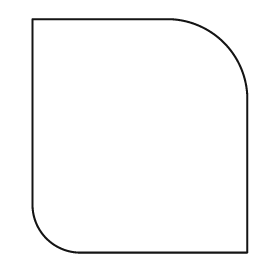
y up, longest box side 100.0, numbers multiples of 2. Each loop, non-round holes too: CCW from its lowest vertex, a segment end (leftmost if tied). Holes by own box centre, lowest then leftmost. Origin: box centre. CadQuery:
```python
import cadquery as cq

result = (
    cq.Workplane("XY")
    .moveTo(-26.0, -50.0)
    .lineTo(46.0, -50.0)
    .lineTo(46.0, 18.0)
    .threePointArc((36.0, 40.0), (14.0, 50.0))
    .lineTo(-46.0, 50.0)
    .lineTo(-46.0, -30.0)
    .threePointArc((-40.0, -44.0), (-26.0, -50.0))
    .close()
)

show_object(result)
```